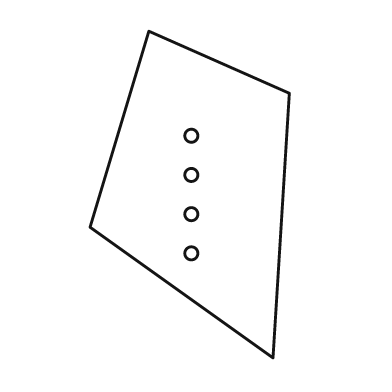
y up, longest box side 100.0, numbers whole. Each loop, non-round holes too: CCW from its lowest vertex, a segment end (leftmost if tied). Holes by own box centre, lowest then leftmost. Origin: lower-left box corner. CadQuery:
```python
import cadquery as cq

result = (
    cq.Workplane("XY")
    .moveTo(56.0, 0.0)
    .lineTo(61.0, 81.0)
    .lineTo(18.0, 100.0)
    .lineTo(0.0, 40.0)
    .close()
    .moveTo(31.0, 32.0)
    .circle(2.0)
    .moveTo(31.0, 44.0)
    .circle(2.0)
    .moveTo(31.0, 56.0)
    .circle(2.0)
    .moveTo(31.0, 68.0)
    .circle(2.0)
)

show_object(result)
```